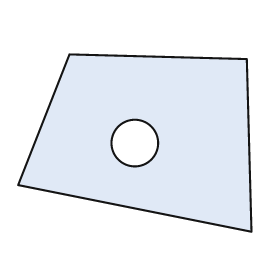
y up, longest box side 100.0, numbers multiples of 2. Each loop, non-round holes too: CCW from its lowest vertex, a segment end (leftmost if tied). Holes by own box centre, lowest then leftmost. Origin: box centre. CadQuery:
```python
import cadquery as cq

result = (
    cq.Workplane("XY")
    .moveTo(50.0, -38.0)
    .lineTo(48.0, 36.0)
    .lineTo(-28.0, 38.0)
    .lineTo(-50.0, -18.0)
    .close()
    .moveTo(0.0, 0.0)
    .circle(10.0)
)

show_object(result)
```